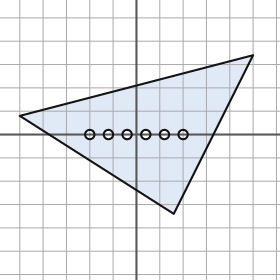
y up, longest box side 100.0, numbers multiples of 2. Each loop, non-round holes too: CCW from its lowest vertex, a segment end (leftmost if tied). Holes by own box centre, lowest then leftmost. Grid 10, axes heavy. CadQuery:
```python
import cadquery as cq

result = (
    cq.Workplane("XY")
    .moveTo(16.0, -34.0)
    .lineTo(50.0, 34.0)
    .lineTo(-50.0, 8.0)
    .close()
    .moveTo(-20.0, 0.0)
    .circle(2.0)
    .moveTo(-12.0, 0.0)
    .circle(2.0)
    .moveTo(-4.0, 0.0)
    .circle(2.0)
    .moveTo(4.0, 0.0)
    .circle(2.0)
    .moveTo(12.0, 0.0)
    .circle(2.0)
    .moveTo(20.0, 0.0)
    .circle(2.0)
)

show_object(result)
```